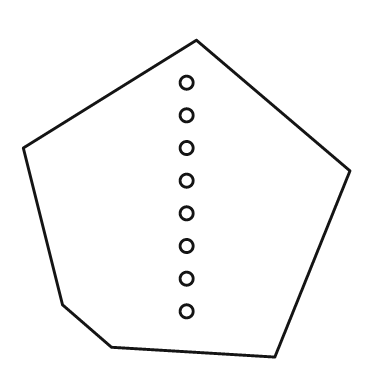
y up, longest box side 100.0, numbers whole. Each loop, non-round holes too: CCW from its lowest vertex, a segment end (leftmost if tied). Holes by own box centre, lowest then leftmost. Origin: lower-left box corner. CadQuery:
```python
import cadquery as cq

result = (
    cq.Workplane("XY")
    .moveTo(77.0, 0.0)
    .lineTo(100.0, 57.0)
    .lineTo(53.0, 97.0)
    .lineTo(0.0, 64.0)
    .lineTo(12.0, 16.0)
    .lineTo(27.0, 3.0)
    .close()
    .moveTo(50.0, 14.0)
    .circle(2.0)
    .moveTo(50.0, 24.0)
    .circle(2.0)
    .moveTo(50.0, 34.0)
    .circle(2.0)
    .moveTo(50.0, 44.0)
    .circle(2.0)
    .moveTo(50.0, 54.0)
    .circle(2.0)
    .moveTo(50.0, 64.0)
    .circle(2.0)
    .moveTo(50.0, 74.0)
    .circle(2.0)
    .moveTo(50.0, 84.0)
    .circle(2.0)
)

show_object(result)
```